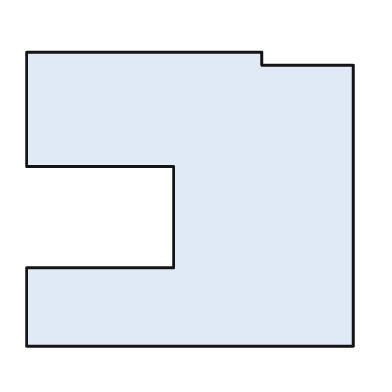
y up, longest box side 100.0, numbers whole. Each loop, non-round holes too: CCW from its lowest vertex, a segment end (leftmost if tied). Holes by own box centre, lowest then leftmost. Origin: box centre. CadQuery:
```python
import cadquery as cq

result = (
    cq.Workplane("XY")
    .moveTo(-50.0, -45.0)
    .lineTo(50.0, -45.0)
    .lineTo(50.0, 41.0)
    .lineTo(22.0, 41.0)
    .lineTo(22.0, 45.0)
    .lineTo(-50.0, 45.0)
    .lineTo(-50.0, 10.0)
    .lineTo(-5.0, 10.0)
    .lineTo(-5.0, -21.0)
    .lineTo(-50.0, -21.0)
    .close()
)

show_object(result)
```